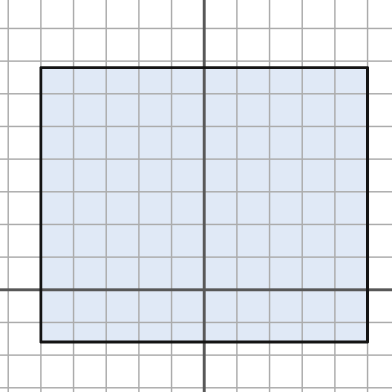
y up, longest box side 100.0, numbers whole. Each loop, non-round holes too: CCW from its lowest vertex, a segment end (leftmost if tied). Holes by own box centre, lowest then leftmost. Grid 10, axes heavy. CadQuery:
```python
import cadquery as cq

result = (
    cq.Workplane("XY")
    .moveTo(-50.0, -16.0)
    .lineTo(50.0, -16.0)
    .lineTo(50.0, 68.0)
    .lineTo(-50.0, 68.0)
    .close()
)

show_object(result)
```